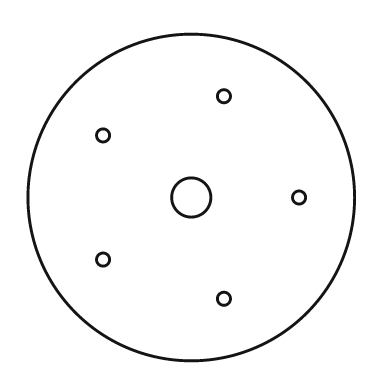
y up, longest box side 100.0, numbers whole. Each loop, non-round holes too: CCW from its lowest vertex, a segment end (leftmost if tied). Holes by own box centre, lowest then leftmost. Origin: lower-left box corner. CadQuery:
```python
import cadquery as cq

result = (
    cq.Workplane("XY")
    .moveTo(50.0, 50.0)
    .circle(50.0)
    .moveTo(60.0, 19.0)
    .circle(2.0)
    .moveTo(23.0, 31.0)
    .circle(2.0)
    .moveTo(50.0, 50.0)
    .circle(6.0)
    .moveTo(83.0, 50.0)
    .circle(2.0)
    .moveTo(23.0, 69.0)
    .circle(2.0)
    .moveTo(60.0, 81.0)
    .circle(2.0)
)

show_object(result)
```